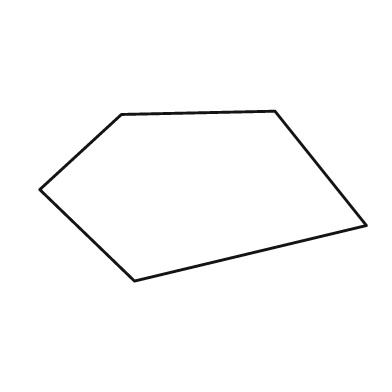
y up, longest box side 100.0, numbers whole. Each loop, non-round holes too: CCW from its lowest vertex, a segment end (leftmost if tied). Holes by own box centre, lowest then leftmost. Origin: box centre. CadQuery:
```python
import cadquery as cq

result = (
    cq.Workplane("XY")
    .moveTo(-21.0, -26.0)
    .lineTo(50.0, -9.0)
    .lineTo(22.0, 26.0)
    .lineTo(-25.0, 25.0)
    .lineTo(-50.0, 2.0)
    .close()
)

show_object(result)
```